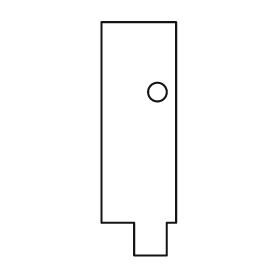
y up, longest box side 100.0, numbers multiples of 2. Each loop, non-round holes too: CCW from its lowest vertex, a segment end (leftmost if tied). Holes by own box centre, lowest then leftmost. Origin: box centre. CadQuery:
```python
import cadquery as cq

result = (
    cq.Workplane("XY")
    .moveTo(-2.0, -50.0)
    .lineTo(12.0, -50.0)
    .lineTo(12.0, -36.0)
    .lineTo(16.0, -36.0)
    .lineTo(16.0, 50.0)
    .lineTo(-16.0, 50.0)
    .lineTo(-16.0, -36.0)
    .lineTo(-2.0, -36.0)
    .close()
    .moveTo(8.0, 20.0)
    .circle(4.0)
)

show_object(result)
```